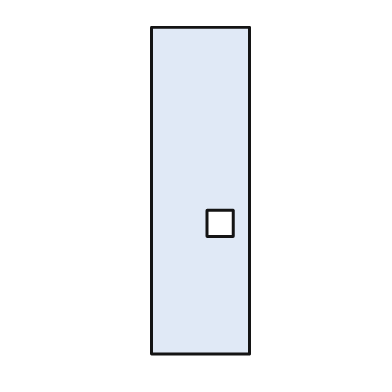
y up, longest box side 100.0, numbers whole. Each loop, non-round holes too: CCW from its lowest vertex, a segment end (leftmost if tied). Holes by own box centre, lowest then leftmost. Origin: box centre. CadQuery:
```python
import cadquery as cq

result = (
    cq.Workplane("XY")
    .moveTo(-15.0, -50.0)
    .lineTo(15.0, -50.0)
    .lineTo(15.0, 50.0)
    .lineTo(-15.0, 50.0)
    .close()
    .moveTo(2.0, -14.0)
    .lineTo(10.0, -14.0)
    .lineTo(10.0, -6.0)
    .lineTo(2.0, -6.0)
    .close()
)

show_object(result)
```